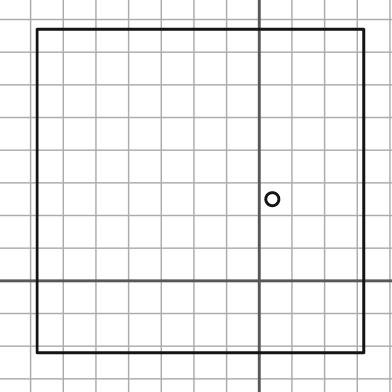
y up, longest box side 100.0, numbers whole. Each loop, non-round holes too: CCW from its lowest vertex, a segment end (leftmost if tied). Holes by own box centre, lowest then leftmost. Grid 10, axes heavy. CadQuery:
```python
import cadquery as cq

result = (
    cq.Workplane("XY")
    .moveTo(-68.0, -22.0)
    .lineTo(32.0, -22.0)
    .lineTo(32.0, 77.0)
    .lineTo(-68.0, 77.0)
    .close()
    .moveTo(4.0, 25.0)
    .circle(2.0)
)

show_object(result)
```